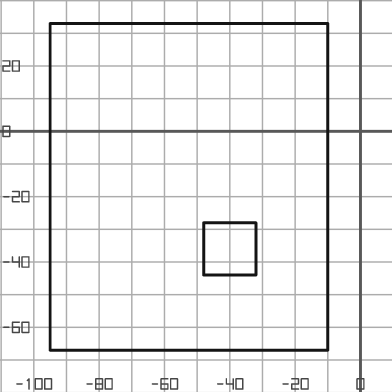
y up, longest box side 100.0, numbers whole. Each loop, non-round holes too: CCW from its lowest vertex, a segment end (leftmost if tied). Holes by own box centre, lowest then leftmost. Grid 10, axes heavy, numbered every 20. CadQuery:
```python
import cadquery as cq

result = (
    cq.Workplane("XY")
    .moveTo(-95.0, -67.0)
    .lineTo(-10.0, -67.0)
    .lineTo(-10.0, 33.0)
    .lineTo(-95.0, 33.0)
    .close()
    .moveTo(-48.0, -44.0)
    .lineTo(-32.0, -44.0)
    .lineTo(-32.0, -28.0)
    .lineTo(-48.0, -28.0)
    .close()
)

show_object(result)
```